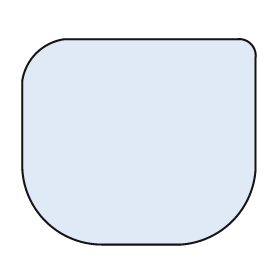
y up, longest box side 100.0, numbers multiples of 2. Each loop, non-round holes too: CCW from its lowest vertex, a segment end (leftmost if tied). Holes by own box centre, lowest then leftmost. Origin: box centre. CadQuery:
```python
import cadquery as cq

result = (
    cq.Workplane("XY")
    .moveTo(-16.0, -44.0)
    .lineTo(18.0, -44.0)
    .threePointArc((40.0, -34.0), (50.0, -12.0))
    .lineTo(50.0, 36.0)
    .threePointArc((48.0, 42.0), (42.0, 44.0))
    .lineTo(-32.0, 44.0)
    .threePointArc((-44.0, 38.0), (-50.0, 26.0))
    .lineTo(-50.0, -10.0)
    .threePointArc((-40.0, -34.0), (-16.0, -44.0))
    .close()
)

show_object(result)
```